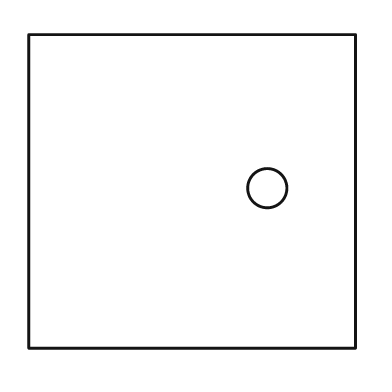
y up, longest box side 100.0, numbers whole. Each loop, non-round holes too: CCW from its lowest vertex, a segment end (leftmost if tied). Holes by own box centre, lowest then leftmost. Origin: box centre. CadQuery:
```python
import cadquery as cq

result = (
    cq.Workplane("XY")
    .moveTo(-50.0, -48.0)
    .lineTo(50.0, -48.0)
    .lineTo(50.0, 48.0)
    .lineTo(-50.0, 48.0)
    .close()
    .moveTo(23.0, 1.0)
    .circle(6.0)
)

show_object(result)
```